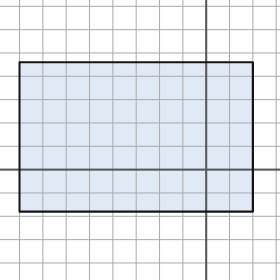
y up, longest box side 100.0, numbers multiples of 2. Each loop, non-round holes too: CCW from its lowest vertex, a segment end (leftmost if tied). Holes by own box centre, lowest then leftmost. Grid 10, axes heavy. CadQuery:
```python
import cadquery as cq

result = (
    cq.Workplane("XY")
    .moveTo(-80.0, -18.0)
    .lineTo(20.0, -18.0)
    .lineTo(20.0, 46.0)
    .lineTo(-80.0, 46.0)
    .close()
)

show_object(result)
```